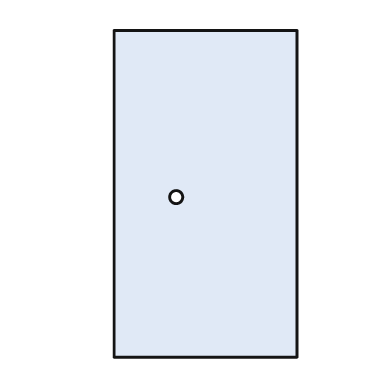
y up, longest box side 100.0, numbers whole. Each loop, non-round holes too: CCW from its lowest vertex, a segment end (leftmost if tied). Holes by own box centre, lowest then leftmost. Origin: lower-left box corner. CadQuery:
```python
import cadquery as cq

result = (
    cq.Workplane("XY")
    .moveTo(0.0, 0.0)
    .lineTo(56.0, 0.0)
    .lineTo(56.0, 100.0)
    .lineTo(0.0, 100.0)
    .close()
    .moveTo(19.0, 49.0)
    .circle(2.0)
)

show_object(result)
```